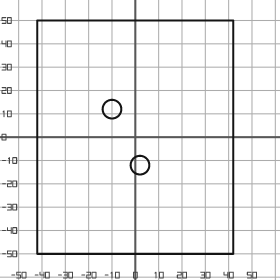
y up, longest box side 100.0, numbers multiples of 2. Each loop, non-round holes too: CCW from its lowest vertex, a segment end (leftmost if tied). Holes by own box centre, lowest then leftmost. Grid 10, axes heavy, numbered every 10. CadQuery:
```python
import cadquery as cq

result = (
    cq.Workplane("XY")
    .moveTo(-42.0, -50.0)
    .lineTo(42.0, -50.0)
    .lineTo(42.0, 50.0)
    .lineTo(-42.0, 50.0)
    .close()
    .moveTo(2.0, -12.0)
    .circle(4.0)
    .moveTo(-10.0, 12.0)
    .circle(4.0)
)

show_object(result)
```